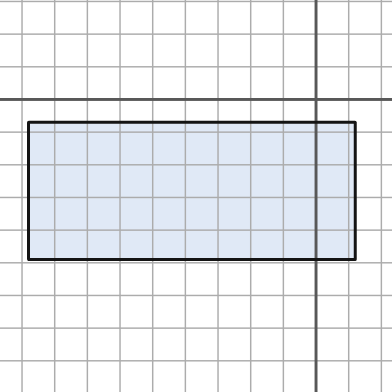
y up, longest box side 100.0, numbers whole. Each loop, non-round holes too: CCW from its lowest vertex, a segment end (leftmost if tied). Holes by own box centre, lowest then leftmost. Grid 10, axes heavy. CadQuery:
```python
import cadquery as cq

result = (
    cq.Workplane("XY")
    .moveTo(-88.0, -49.0)
    .lineTo(12.0, -49.0)
    .lineTo(12.0, -7.0)
    .lineTo(-88.0, -7.0)
    .close()
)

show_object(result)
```